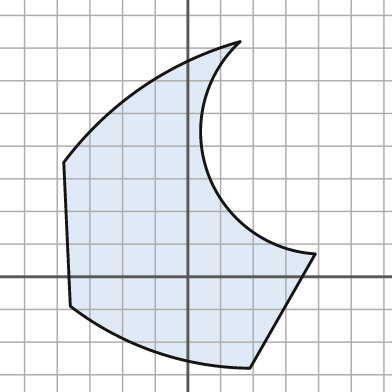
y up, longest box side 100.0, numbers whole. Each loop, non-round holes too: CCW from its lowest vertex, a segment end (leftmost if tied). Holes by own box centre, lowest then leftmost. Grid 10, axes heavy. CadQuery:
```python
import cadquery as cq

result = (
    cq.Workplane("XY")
    .moveTo(19.0, -28.0)
    .lineTo(39.0, 7.0)
    .threePointArc((6.0, 32.0), (16.0, 72.0))
    .threePointArc((-14.0, 58.0), (-38.0, 35.0))
    .lineTo(-36.0, -9.0)
    .threePointArc((-10.0, -23.0), (19.0, -28.0))
    .close()
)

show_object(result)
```